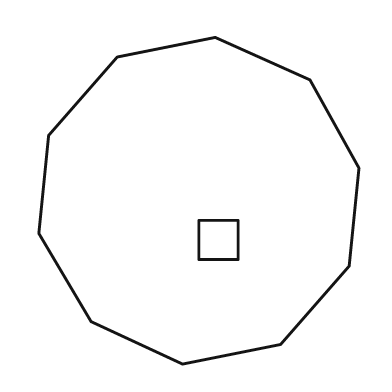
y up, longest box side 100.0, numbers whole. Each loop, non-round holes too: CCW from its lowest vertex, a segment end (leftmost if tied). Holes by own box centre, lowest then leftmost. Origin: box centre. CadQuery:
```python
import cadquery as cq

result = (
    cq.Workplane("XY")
    .moveTo(-5.0, -50.0)
    .lineTo(25.0, -44.0)
    .lineTo(46.0, -20.0)
    .lineTo(49.0, 10.0)
    .lineTo(34.0, 37.0)
    .lineTo(5.0, 50.0)
    .lineTo(-25.0, 44.0)
    .lineTo(-46.0, 20.0)
    .lineTo(-49.0, -10.0)
    .lineTo(-33.0, -37.0)
    .close()
    .moveTo(0.0, -18.0)
    .lineTo(12.0, -18.0)
    .lineTo(12.0, -6.0)
    .lineTo(0.0, -6.0)
    .close()
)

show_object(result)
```